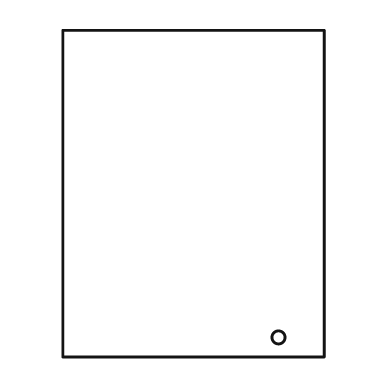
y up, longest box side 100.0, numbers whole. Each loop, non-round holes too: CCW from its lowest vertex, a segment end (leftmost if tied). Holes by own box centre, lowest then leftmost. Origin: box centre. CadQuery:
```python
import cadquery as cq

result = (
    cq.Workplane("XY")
    .moveTo(-40.0, -50.0)
    .lineTo(40.0, -50.0)
    .lineTo(40.0, 50.0)
    .lineTo(-40.0, 50.0)
    .close()
    .moveTo(26.0, -44.0)
    .circle(2.0)
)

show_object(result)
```